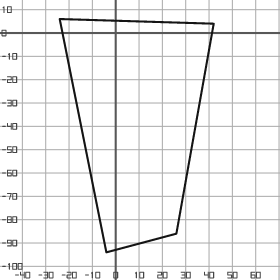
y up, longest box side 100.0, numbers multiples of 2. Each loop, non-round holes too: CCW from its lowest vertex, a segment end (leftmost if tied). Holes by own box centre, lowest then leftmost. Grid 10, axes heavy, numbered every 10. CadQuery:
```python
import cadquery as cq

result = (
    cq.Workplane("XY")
    .moveTo(-4.0, -94.0)
    .lineTo(26.0, -86.0)
    .lineTo(42.0, 4.0)
    .lineTo(-24.0, 6.0)
    .close()
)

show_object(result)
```